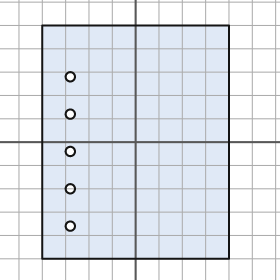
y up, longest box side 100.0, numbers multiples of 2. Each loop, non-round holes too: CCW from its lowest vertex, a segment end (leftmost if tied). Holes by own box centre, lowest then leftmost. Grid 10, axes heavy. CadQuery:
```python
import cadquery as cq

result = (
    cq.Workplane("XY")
    .moveTo(-40.0, -50.0)
    .lineTo(40.0, -50.0)
    .lineTo(40.0, 50.0)
    .lineTo(-40.0, 50.0)
    .close()
    .moveTo(-28.0, -36.0)
    .circle(2.0)
    .moveTo(-28.0, -20.0)
    .circle(2.0)
    .moveTo(-28.0, -4.0)
    .circle(2.0)
    .moveTo(-28.0, 12.0)
    .circle(2.0)
    .moveTo(-28.0, 28.0)
    .circle(2.0)
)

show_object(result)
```